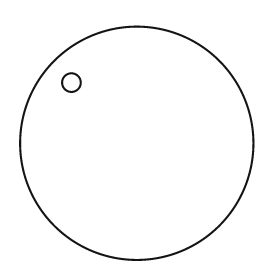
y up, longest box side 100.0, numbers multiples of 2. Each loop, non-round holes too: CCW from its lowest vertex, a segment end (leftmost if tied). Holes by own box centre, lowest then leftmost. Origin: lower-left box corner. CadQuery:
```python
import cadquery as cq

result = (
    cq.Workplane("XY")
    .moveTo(50.0, 50.0)
    .circle(50.0)
    .moveTo(22.0, 76.0)
    .circle(4.0)
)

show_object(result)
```